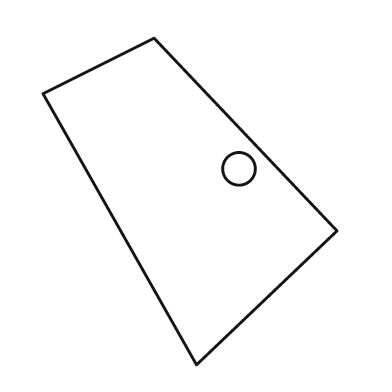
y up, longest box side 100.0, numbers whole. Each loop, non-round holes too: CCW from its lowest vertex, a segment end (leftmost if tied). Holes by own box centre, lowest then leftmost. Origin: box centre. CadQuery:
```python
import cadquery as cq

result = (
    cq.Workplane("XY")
    .moveTo(2.0, -50.0)
    .lineTo(45.0, -9.0)
    .lineTo(-11.0, 50.0)
    .lineTo(-45.0, 33.0)
    .close()
    .moveTo(15.0, 10.0)
    .circle(5.0)
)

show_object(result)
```